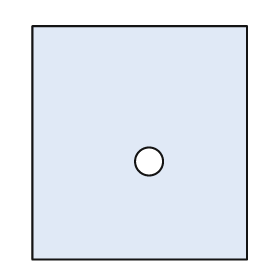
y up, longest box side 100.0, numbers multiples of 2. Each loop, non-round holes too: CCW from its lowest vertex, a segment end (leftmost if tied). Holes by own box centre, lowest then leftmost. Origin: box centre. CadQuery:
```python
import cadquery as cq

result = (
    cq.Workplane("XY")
    .moveTo(-46.0, -50.0)
    .lineTo(46.0, -50.0)
    .lineTo(46.0, 50.0)
    .lineTo(-46.0, 50.0)
    .close()
    .moveTo(4.0, -8.0)
    .circle(6.0)
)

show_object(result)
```